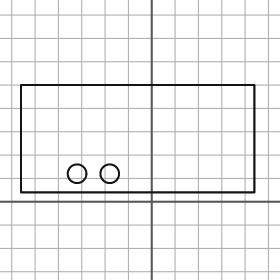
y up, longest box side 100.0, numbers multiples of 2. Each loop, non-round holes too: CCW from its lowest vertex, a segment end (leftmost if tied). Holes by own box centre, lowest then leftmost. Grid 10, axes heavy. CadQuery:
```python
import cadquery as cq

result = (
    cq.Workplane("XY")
    .moveTo(-56.0, 4.0)
    .lineTo(44.0, 4.0)
    .lineTo(44.0, 50.0)
    .lineTo(-56.0, 50.0)
    .close()
    .moveTo(-32.0, 12.0)
    .circle(4.0)
    .moveTo(-18.0, 12.0)
    .circle(4.0)
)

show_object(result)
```